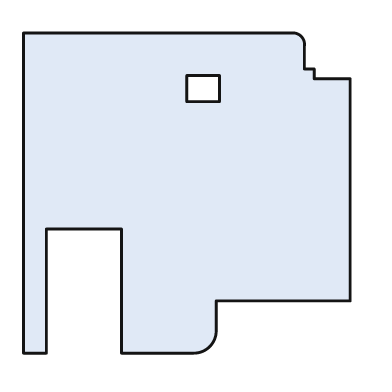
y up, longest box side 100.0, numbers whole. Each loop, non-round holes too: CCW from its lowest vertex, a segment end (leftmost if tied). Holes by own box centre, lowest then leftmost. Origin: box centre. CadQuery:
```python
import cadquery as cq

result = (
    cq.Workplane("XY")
    .moveTo(-50.0, -49.0)
    .lineTo(-43.0, -49.0)
    .lineTo(-43.0, -11.0)
    .lineTo(-20.0, -11.0)
    .lineTo(-20.0, -49.0)
    .lineTo(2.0, -49.0)
    .threePointArc((7.0, -47.0), (9.0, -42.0))
    .lineTo(9.0, -33.0)
    .lineTo(50.0, -33.0)
    .lineTo(50.0, 35.0)
    .lineTo(39.0, 35.0)
    .lineTo(39.0, 38.0)
    .lineTo(36.0, 38.0)
    .lineTo(36.0, 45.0)
    .threePointArc((35.0, 48.0), (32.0, 49.0))
    .lineTo(-50.0, 49.0)
    .close()
    .moveTo(0.0, 28.0)
    .lineTo(10.0, 28.0)
    .lineTo(10.0, 36.0)
    .lineTo(0.0, 36.0)
    .close()
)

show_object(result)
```